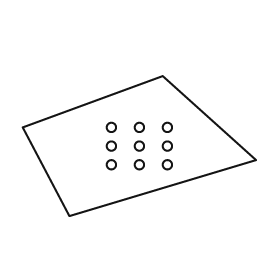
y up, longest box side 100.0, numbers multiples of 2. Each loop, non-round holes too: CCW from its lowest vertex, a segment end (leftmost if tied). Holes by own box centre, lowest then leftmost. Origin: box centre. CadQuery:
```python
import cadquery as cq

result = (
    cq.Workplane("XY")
    .moveTo(-30.0, -30.0)
    .lineTo(50.0, -6.0)
    .lineTo(10.0, 30.0)
    .lineTo(-50.0, 8.0)
    .close()
    .moveTo(-12.0, -8.0)
    .circle(2.0)
    .moveTo(0.0, -8.0)
    .circle(2.0)
    .moveTo(12.0, -8.0)
    .circle(2.0)
    .moveTo(-12.0, 0.0)
    .circle(2.0)
    .moveTo(0.0, 0.0)
    .circle(2.0)
    .moveTo(12.0, 0.0)
    .circle(2.0)
    .moveTo(-12.0, 8.0)
    .circle(2.0)
    .moveTo(0.0, 8.0)
    .circle(2.0)
    .moveTo(12.0, 8.0)
    .circle(2.0)
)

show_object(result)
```